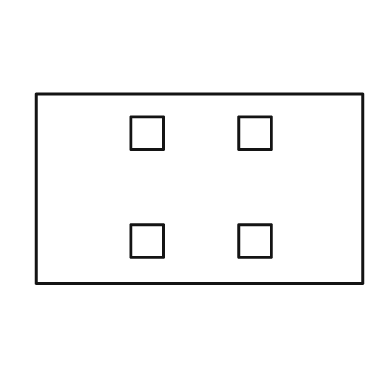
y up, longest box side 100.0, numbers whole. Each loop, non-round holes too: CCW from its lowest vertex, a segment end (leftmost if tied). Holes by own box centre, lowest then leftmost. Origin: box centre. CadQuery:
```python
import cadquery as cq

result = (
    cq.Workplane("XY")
    .moveTo(-50.0, -29.0)
    .lineTo(50.0, -29.0)
    .lineTo(50.0, 29.0)
    .lineTo(-50.0, 29.0)
    .close()
    .moveTo(-21.0, -21.0)
    .lineTo(-11.0, -21.0)
    .lineTo(-11.0, -11.0)
    .lineTo(-21.0, -11.0)
    .close()
    .moveTo(12.0, -21.0)
    .lineTo(22.0, -21.0)
    .lineTo(22.0, -11.0)
    .lineTo(12.0, -11.0)
    .close()
    .moveTo(-21.0, 12.0)
    .lineTo(-11.0, 12.0)
    .lineTo(-11.0, 22.0)
    .lineTo(-21.0, 22.0)
    .close()
    .moveTo(12.0, 12.0)
    .lineTo(22.0, 12.0)
    .lineTo(22.0, 22.0)
    .lineTo(12.0, 22.0)
    .close()
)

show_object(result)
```